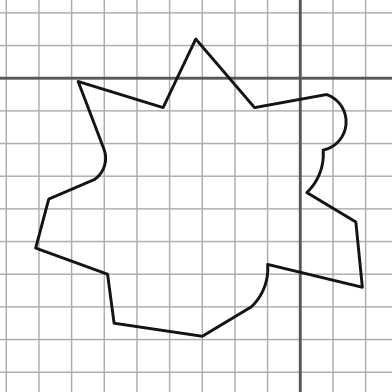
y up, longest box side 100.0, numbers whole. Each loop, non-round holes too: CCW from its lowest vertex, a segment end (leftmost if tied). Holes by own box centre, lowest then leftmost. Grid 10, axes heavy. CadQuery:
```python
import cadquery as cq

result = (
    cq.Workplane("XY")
    .moveTo(-30.0, -79.0)
    .lineTo(-15.0, -70.0)
    .threePointArc((-11.0, -64.0), (-10.0, -57.0))
    .lineTo(19.0, -64.0)
    .lineTo(17.0, -44.0)
    .lineTo(2.0, -35.0)
    .threePointArc((6.0, -29.0), (7.0, -22.0))
    .threePointArc((14.0, -14.0), (8.0, -5.0))
    .lineTo(-14.0, -9.0)
    .lineTo(-32.0, 12.0)
    .lineTo(-42.0, -9.0)
    .lineTo(-68.0, -1.0)
    .lineTo(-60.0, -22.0)
    .threePointArc((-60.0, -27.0), (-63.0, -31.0))
    .lineTo(-77.0, -37.0)
    .lineTo(-81.0, -52.0)
    .lineTo(-59.0, -60.0)
    .lineTo(-57.0, -75.0)
    .close()
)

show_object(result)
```